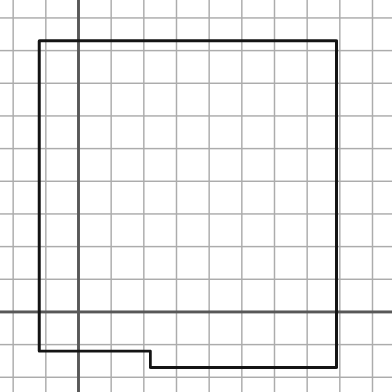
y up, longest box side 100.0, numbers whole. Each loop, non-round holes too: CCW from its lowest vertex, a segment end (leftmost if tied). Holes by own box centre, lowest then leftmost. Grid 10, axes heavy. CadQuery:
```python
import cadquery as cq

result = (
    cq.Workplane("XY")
    .moveTo(22.0, -17.0)
    .lineTo(79.0, -17.0)
    .lineTo(79.0, 83.0)
    .lineTo(-12.0, 83.0)
    .lineTo(-12.0, -12.0)
    .lineTo(22.0, -12.0)
    .close()
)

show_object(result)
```